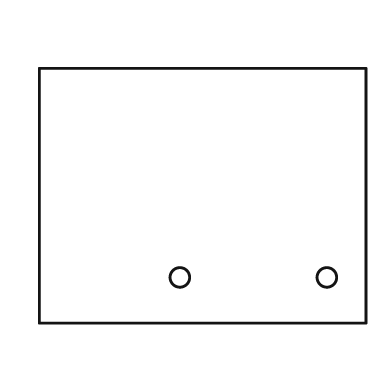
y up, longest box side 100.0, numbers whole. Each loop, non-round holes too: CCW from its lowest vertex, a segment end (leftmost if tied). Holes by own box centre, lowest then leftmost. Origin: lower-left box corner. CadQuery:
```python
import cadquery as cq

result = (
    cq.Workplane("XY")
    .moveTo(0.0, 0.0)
    .lineTo(100.0, 0.0)
    .lineTo(100.0, 78.0)
    .lineTo(0.0, 78.0)
    .close()
    .moveTo(43.0, 14.0)
    .circle(3.0)
    .moveTo(88.0, 14.0)
    .circle(3.0)
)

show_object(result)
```